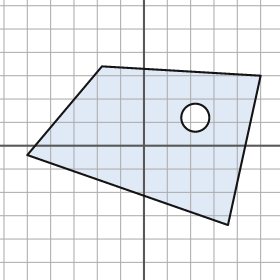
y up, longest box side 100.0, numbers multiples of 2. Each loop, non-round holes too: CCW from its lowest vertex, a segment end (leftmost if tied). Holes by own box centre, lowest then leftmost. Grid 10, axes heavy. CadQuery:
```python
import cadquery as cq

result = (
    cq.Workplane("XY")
    .moveTo(36.0, -34.0)
    .lineTo(50.0, 30.0)
    .lineTo(-18.0, 34.0)
    .lineTo(-50.0, -4.0)
    .close()
    .moveTo(22.0, 12.0)
    .circle(6.0)
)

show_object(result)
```